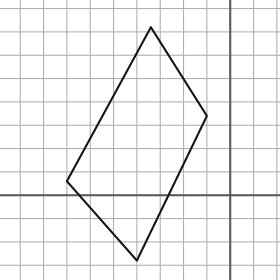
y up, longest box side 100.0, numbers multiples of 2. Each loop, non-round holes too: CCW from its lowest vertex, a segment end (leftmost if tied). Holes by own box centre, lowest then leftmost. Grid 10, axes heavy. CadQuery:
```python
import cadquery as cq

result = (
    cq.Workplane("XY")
    .moveTo(-40.0, -28.0)
    .lineTo(-10.0, 34.0)
    .lineTo(-34.0, 72.0)
    .lineTo(-70.0, 6.0)
    .close()
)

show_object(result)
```